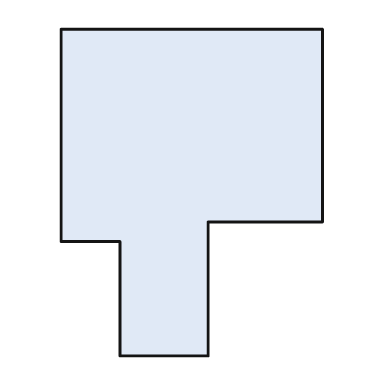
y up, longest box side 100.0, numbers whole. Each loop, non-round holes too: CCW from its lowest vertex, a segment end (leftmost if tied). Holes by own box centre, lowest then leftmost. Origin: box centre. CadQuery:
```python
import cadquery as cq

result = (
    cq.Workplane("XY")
    .moveTo(-22.0, -50.0)
    .lineTo(5.0, -50.0)
    .lineTo(5.0, -9.0)
    .lineTo(40.0, -9.0)
    .lineTo(40.0, 50.0)
    .lineTo(-40.0, 50.0)
    .lineTo(-40.0, -15.0)
    .lineTo(-22.0, -15.0)
    .close()
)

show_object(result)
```